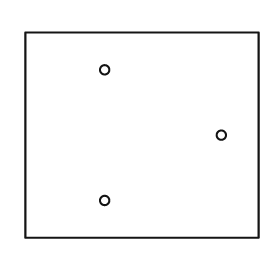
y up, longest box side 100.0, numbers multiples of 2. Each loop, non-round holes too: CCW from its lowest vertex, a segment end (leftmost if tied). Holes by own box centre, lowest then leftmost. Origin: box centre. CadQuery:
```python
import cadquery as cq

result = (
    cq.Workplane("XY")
    .moveTo(-50.0, -44.0)
    .lineTo(50.0, -44.0)
    .lineTo(50.0, 44.0)
    .lineTo(-50.0, 44.0)
    .close()
    .moveTo(-16.0, -28.0)
    .circle(2.0)
    .moveTo(34.0, 0.0)
    .circle(2.0)
    .moveTo(-16.0, 28.0)
    .circle(2.0)
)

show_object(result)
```